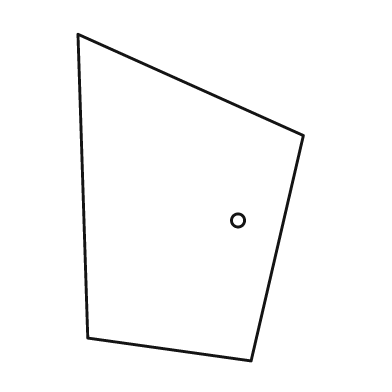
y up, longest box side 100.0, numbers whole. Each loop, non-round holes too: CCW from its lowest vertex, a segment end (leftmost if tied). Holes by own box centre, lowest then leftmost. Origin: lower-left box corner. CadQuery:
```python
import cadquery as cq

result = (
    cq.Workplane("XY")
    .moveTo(53.0, 0.0)
    .lineTo(69.0, 69.0)
    .lineTo(0.0, 100.0)
    .lineTo(3.0, 7.0)
    .close()
    .moveTo(49.0, 43.0)
    .circle(2.0)
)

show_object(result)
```